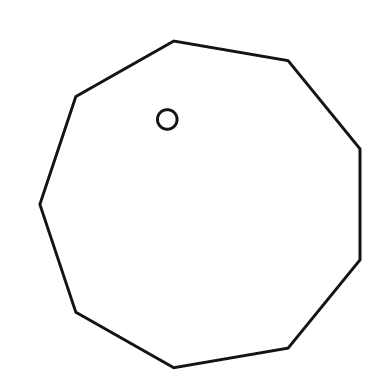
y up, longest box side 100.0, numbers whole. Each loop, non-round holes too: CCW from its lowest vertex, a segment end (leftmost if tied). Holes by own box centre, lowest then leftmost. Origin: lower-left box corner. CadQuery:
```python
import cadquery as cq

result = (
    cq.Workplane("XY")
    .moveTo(41.0, 0.0)
    .lineTo(76.0, 6.0)
    .lineTo(98.0, 33.0)
    .lineTo(98.0, 67.0)
    .lineTo(76.0, 94.0)
    .lineTo(41.0, 100.0)
    .lineTo(11.0, 83.0)
    .lineTo(0.0, 50.0)
    .lineTo(11.0, 17.0)
    .close()
    .moveTo(39.0, 76.0)
    .circle(3.0)
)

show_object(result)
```